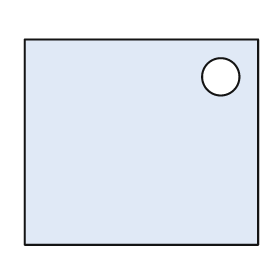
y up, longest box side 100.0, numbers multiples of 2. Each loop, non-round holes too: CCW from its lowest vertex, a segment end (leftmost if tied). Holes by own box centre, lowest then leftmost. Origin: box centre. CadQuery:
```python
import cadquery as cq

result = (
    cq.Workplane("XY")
    .moveTo(-50.0, -44.0)
    .lineTo(50.0, -44.0)
    .lineTo(50.0, 44.0)
    .lineTo(-50.0, 44.0)
    .close()
    .moveTo(34.0, 28.0)
    .circle(8.0)
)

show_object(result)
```